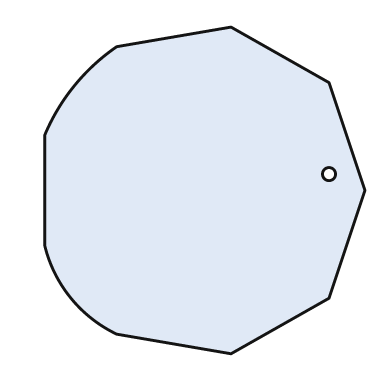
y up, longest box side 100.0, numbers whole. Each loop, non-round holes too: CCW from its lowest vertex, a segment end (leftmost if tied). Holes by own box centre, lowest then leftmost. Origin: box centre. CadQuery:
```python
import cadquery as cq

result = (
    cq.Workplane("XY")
    .moveTo(8.0, -50.0)
    .lineTo(38.0, -33.0)
    .lineTo(49.0, 0.0)
    .lineTo(38.0, 33.0)
    .lineTo(8.0, 50.0)
    .lineTo(-27.0, 44.0)
    .threePointArc((-40.0, 32.0), (-49.0, 17.0))
    .lineTo(-49.0, -17.0)
    .threePointArc((-41.0, -33.0), (-27.0, -44.0))
    .close()
    .moveTo(38.0, 5.0)
    .circle(2.0)
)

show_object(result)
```